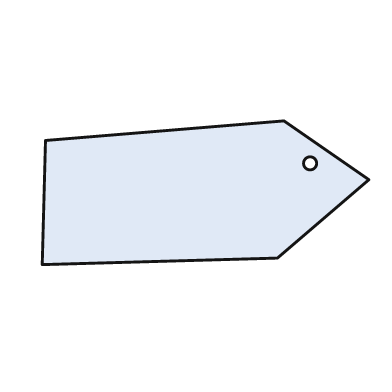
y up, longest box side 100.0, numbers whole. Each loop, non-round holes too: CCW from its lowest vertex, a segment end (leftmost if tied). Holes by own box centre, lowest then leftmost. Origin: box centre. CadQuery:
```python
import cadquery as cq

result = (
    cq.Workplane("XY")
    .moveTo(-50.0, -22.0)
    .lineTo(22.0, -20.0)
    .lineTo(50.0, 4.0)
    .lineTo(24.0, 22.0)
    .lineTo(-49.0, 16.0)
    .close()
    .moveTo(32.0, 9.0)
    .circle(2.0)
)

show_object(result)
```